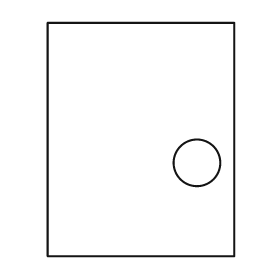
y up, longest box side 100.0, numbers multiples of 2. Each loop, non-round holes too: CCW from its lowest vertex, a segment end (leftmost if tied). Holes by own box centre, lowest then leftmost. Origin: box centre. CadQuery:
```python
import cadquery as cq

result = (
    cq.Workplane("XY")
    .moveTo(-40.0, -50.0)
    .lineTo(40.0, -50.0)
    .lineTo(40.0, 50.0)
    .lineTo(-40.0, 50.0)
    .close()
    .moveTo(24.0, -10.0)
    .circle(10.0)
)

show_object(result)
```